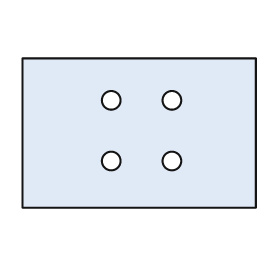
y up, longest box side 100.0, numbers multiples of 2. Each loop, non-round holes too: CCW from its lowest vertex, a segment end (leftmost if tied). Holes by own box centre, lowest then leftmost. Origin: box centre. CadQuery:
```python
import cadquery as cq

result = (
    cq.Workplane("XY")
    .moveTo(-50.0, -32.0)
    .lineTo(50.0, -32.0)
    .lineTo(50.0, 32.0)
    .lineTo(-50.0, 32.0)
    .close()
    .moveTo(-12.0, -12.0)
    .circle(4.0)
    .moveTo(14.0, -12.0)
    .circle(4.0)
    .moveTo(-12.0, 14.0)
    .circle(4.0)
    .moveTo(14.0, 14.0)
    .circle(4.0)
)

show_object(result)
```